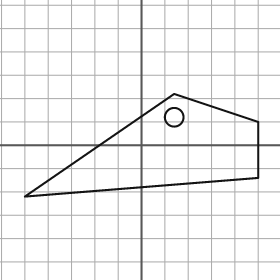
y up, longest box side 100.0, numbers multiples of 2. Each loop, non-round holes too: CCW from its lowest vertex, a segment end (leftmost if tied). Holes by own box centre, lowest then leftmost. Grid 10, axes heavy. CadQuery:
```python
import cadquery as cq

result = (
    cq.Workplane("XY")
    .moveTo(-50.0, -22.0)
    .lineTo(50.0, -14.0)
    .lineTo(50.0, 10.0)
    .lineTo(14.0, 22.0)
    .close()
    .moveTo(14.0, 12.0)
    .circle(4.0)
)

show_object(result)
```